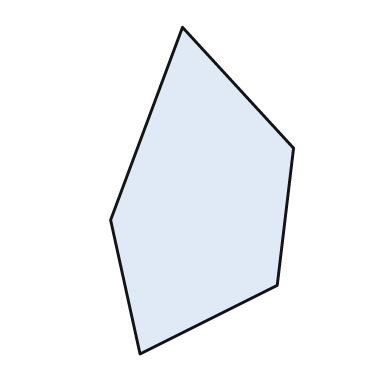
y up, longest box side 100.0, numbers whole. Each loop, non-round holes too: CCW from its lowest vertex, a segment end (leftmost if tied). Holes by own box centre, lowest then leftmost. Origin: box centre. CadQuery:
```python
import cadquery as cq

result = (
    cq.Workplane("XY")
    .moveTo(-19.0, -50.0)
    .lineTo(23.0, -29.0)
    .lineTo(28.0, 13.0)
    .lineTo(-6.0, 50.0)
    .lineTo(-28.0, -9.0)
    .close()
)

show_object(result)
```